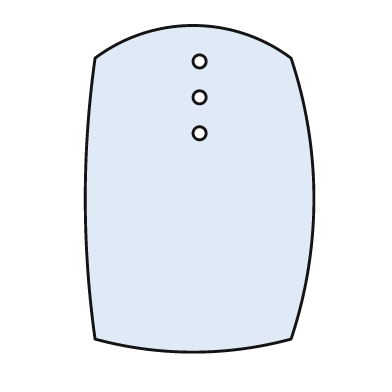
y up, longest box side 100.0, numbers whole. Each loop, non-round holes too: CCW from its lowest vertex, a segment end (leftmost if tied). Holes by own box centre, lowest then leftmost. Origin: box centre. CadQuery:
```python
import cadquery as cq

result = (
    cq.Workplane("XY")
    .moveTo(-32.0, -46.0)
    .threePointArc((-2.0, -50.0), (28.0, -46.0))
    .threePointArc((35.0, -3.0), (28.0, 40.0))
    .threePointArc((-2.0, 50.0), (-32.0, 40.0))
    .threePointArc((-35.0, -3.0), (-32.0, -46.0))
    .close()
    .moveTo(0.0, 17.0)
    .circle(2.0)
    .moveTo(0.0, 28.0)
    .circle(2.0)
    .moveTo(0.0, 39.0)
    .circle(2.0)
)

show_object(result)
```